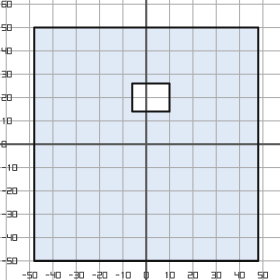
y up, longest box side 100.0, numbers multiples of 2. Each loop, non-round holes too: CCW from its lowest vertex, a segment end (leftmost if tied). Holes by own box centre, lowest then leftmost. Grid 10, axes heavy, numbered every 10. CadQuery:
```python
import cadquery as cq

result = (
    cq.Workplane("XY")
    .moveTo(-48.0, -50.0)
    .lineTo(48.0, -50.0)
    .lineTo(48.0, 50.0)
    .lineTo(-48.0, 50.0)
    .close()
    .moveTo(-6.0, 14.0)
    .lineTo(10.0, 14.0)
    .lineTo(10.0, 26.0)
    .lineTo(-6.0, 26.0)
    .close()
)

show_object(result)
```